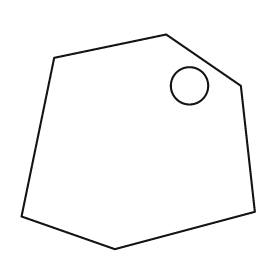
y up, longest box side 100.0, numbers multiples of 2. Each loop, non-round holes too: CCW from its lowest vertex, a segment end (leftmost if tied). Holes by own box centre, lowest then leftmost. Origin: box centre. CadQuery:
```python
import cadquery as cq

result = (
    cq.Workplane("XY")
    .moveTo(-10.0, -46.0)
    .lineTo(50.0, -30.0)
    .lineTo(44.0, 24.0)
    .lineTo(12.0, 46.0)
    .lineTo(-36.0, 36.0)
    .lineTo(-50.0, -32.0)
    .close()
    .moveTo(22.0, 24.0)
    .circle(8.0)
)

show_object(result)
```